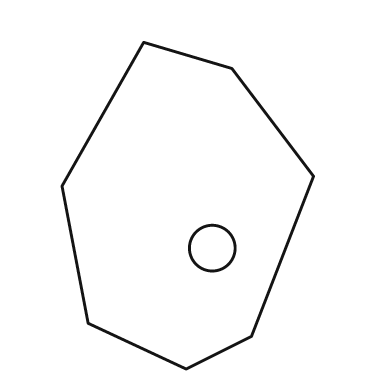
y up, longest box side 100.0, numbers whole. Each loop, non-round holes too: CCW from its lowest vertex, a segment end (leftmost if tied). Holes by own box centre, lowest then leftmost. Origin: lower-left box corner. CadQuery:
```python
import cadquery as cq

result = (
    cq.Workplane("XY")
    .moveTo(38.0, 0.0)
    .lineTo(58.0, 10.0)
    .lineTo(77.0, 59.0)
    .lineTo(52.0, 92.0)
    .lineTo(25.0, 100.0)
    .lineTo(0.0, 56.0)
    .lineTo(8.0, 14.0)
    .close()
    .moveTo(46.0, 37.0)
    .circle(7.0)
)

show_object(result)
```